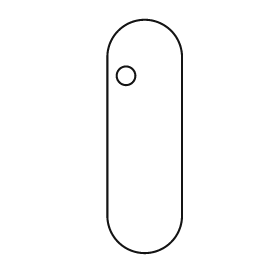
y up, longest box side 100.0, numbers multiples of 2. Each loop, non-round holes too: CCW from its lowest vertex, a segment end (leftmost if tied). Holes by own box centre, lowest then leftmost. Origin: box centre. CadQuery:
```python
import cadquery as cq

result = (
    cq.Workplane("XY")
    .moveTo(-16.0, -34.0)
    .threePointArc((0.0, -50.0), (16.0, -34.0))
    .lineTo(16.0, 34.0)
    .threePointArc((0.0, 50.0), (-16.0, 34.0))
    .close()
    .moveTo(-8.0, 26.0)
    .circle(4.0)
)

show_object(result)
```